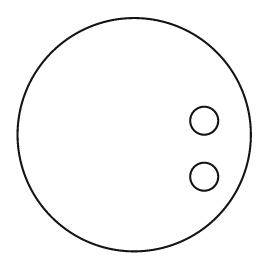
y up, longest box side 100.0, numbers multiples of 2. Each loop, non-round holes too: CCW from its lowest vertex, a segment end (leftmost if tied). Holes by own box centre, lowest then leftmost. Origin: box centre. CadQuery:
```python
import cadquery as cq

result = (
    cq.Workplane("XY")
    .moveTo(0.0, 0.0)
    .circle(50.0)
    .moveTo(30.0, -18.0)
    .circle(6.0)
    .moveTo(30.0, 6.0)
    .circle(6.0)
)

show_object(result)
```